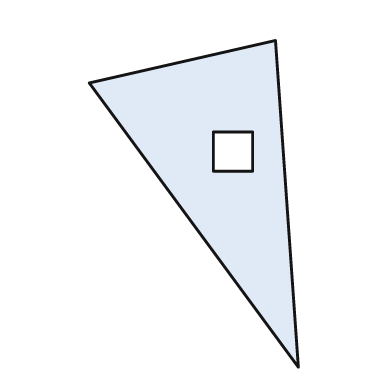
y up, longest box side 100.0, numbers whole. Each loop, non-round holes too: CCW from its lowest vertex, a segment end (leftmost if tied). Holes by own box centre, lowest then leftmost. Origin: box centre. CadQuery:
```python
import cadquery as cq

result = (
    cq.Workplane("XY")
    .moveTo(32.0, -50.0)
    .lineTo(25.0, 50.0)
    .lineTo(-32.0, 37.0)
    .close()
    .moveTo(6.0, 10.0)
    .lineTo(18.0, 10.0)
    .lineTo(18.0, 22.0)
    .lineTo(6.0, 22.0)
    .close()
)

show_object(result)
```